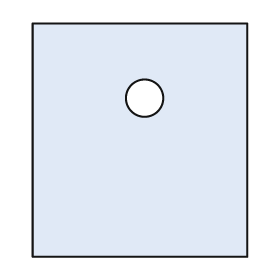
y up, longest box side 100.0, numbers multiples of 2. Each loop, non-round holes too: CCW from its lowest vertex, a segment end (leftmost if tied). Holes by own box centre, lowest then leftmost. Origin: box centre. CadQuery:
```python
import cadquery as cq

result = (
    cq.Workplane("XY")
    .moveTo(-46.0, -50.0)
    .lineTo(46.0, -50.0)
    .lineTo(46.0, 50.0)
    .lineTo(-46.0, 50.0)
    .close()
    .moveTo(2.0, 18.0)
    .circle(8.0)
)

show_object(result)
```